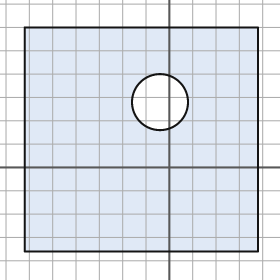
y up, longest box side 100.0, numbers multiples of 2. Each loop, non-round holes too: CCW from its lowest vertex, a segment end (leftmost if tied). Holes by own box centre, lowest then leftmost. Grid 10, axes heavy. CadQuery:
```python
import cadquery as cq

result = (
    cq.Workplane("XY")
    .moveTo(-62.0, -36.0)
    .lineTo(38.0, -36.0)
    .lineTo(38.0, 60.0)
    .lineTo(-62.0, 60.0)
    .close()
    .moveTo(-4.0, 28.0)
    .circle(12.0)
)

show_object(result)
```